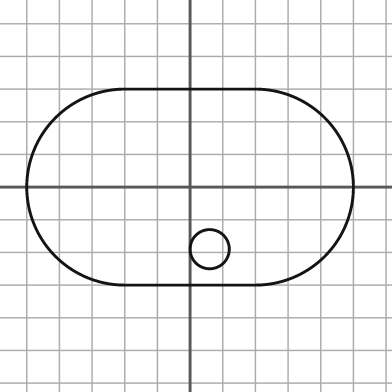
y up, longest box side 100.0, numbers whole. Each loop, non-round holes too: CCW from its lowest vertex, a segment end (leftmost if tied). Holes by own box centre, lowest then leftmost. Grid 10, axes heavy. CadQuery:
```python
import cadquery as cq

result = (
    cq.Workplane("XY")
    .moveTo(-20.0, -30.0)
    .lineTo(20.0, -30.0)
    .threePointArc((50.0, 0.0), (20.0, 30.0))
    .lineTo(-20.0, 30.0)
    .threePointArc((-50.0, 0.0), (-20.0, -30.0))
    .close()
    .moveTo(6.0, -19.0)
    .circle(6.0)
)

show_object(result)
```